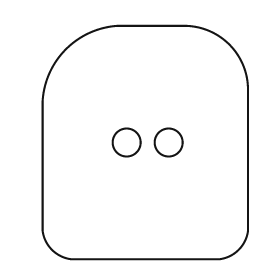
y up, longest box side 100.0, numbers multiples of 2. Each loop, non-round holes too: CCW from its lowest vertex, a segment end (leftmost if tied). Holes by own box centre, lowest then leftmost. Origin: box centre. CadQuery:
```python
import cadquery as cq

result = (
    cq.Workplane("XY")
    .moveTo(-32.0, -50.0)
    .lineTo(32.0, -50.0)
    .threePointArc((40.0, -46.0), (44.0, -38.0))
    .lineTo(44.0, 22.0)
    .threePointArc((36.0, 42.0), (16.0, 50.0))
    .lineTo(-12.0, 50.0)
    .threePointArc((-34.0, 40.0), (-44.0, 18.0))
    .lineTo(-44.0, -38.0)
    .threePointArc((-40.0, -46.0), (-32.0, -50.0))
    .close()
    .moveTo(-8.0, 0.0)
    .circle(6.0)
    .moveTo(10.0, 0.0)
    .circle(6.0)
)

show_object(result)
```